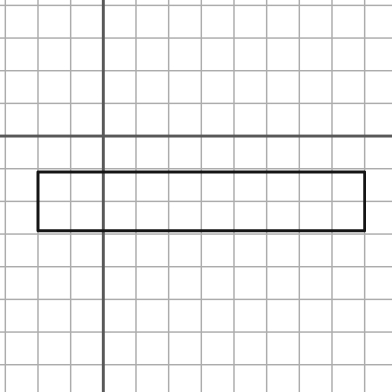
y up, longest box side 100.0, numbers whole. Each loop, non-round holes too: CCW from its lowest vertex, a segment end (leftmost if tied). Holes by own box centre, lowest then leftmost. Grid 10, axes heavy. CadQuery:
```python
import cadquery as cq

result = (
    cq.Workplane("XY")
    .moveTo(-20.0, -29.0)
    .lineTo(80.0, -29.0)
    .lineTo(80.0, -11.0)
    .lineTo(-20.0, -11.0)
    .close()
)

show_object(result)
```